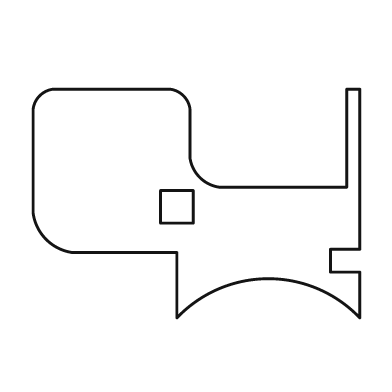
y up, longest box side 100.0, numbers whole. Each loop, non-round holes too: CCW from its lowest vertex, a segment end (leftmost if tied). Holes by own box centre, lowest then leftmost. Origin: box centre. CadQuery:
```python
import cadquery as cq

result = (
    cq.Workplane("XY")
    .moveTo(-6.0, -35.0)
    .threePointArc((22.0, -23.0), (50.0, -35.0))
    .lineTo(50.0, -21.0)
    .lineTo(41.0, -21.0)
    .lineTo(41.0, -14.0)
    .lineTo(50.0, -14.0)
    .lineTo(50.0, 35.0)
    .lineTo(46.0, 35.0)
    .lineTo(46.0, 5.0)
    .lineTo(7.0, 5.0)
    .threePointArc((1.0, 8.0), (-2.0, 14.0))
    .lineTo(-2.0, 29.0)
    .threePointArc((-4.0, 33.0), (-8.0, 35.0))
    .lineTo(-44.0, 35.0)
    .threePointArc((-48.0, 33.0), (-50.0, 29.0))
    .lineTo(-50.0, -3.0)
    .threePointArc((-46.0, -11.0), (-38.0, -15.0))
    .lineTo(-6.0, -15.0)
    .close()
    .moveTo(-11.0, -6.0)
    .lineTo(-1.0, -6.0)
    .lineTo(-1.0, 4.0)
    .lineTo(-11.0, 4.0)
    .close()
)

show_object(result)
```